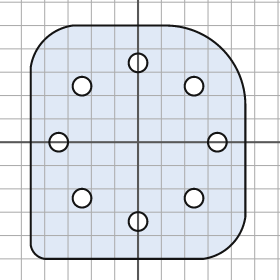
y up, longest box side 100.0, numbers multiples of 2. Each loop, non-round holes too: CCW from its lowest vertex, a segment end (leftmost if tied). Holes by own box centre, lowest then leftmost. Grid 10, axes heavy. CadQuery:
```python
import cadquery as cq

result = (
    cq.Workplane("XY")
    .moveTo(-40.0, -50.0)
    .lineTo(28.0, -50.0)
    .threePointArc((40.0, -44.0), (46.0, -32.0))
    .lineTo(46.0, 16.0)
    .threePointArc((36.0, 40.0), (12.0, 50.0))
    .lineTo(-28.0, 50.0)
    .threePointArc((-40.0, 44.0), (-46.0, 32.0))
    .lineTo(-46.0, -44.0)
    .threePointArc((-44.0, -48.0), (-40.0, -50.0))
    .close()
    .moveTo(0.0, -34.0)
    .circle(4.0)
    .moveTo(-24.0, -24.0)
    .circle(4.0)
    .moveTo(24.0, -24.0)
    .circle(4.0)
    .moveTo(-34.0, 0.0)
    .circle(4.0)
    .moveTo(34.0, 0.0)
    .circle(4.0)
    .moveTo(-24.0, 24.0)
    .circle(4.0)
    .moveTo(24.0, 24.0)
    .circle(4.0)
    .moveTo(0.0, 34.0)
    .circle(4.0)
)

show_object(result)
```